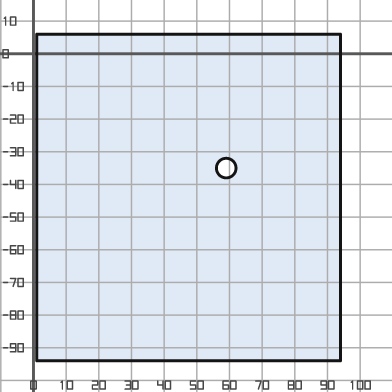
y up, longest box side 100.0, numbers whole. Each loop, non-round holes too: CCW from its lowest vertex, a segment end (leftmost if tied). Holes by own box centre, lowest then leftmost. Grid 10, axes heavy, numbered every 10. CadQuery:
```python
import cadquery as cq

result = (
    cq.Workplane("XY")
    .moveTo(1.0, -94.0)
    .lineTo(94.0, -94.0)
    .lineTo(94.0, 6.0)
    .lineTo(1.0, 6.0)
    .close()
    .moveTo(59.0, -35.0)
    .circle(3.0)
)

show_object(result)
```